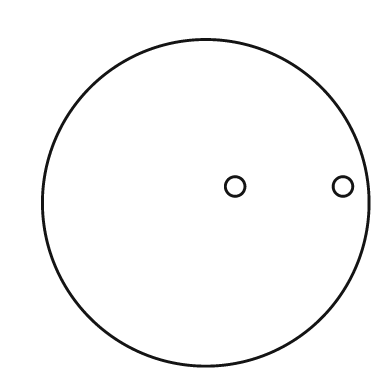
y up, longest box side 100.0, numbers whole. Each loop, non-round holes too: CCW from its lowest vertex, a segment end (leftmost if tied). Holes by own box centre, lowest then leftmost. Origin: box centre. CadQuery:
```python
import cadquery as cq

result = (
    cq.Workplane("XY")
    .moveTo(0.0, 0.0)
    .circle(50.0)
    .moveTo(9.0, 5.0)
    .circle(3.0)
    .moveTo(42.0, 5.0)
    .circle(3.0)
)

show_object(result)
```